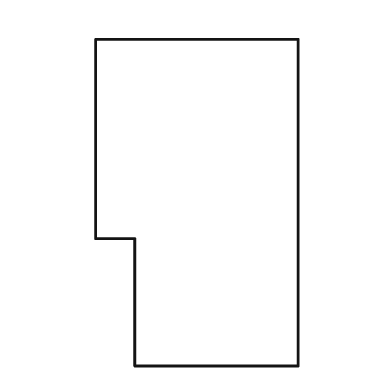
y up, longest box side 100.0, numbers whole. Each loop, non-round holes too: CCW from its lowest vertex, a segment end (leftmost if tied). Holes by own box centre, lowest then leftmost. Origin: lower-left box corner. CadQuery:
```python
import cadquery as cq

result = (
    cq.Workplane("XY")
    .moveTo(12.0, 0.0)
    .lineTo(62.0, 0.0)
    .lineTo(62.0, 100.0)
    .lineTo(0.0, 100.0)
    .lineTo(0.0, 39.0)
    .lineTo(12.0, 39.0)
    .close()
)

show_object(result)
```